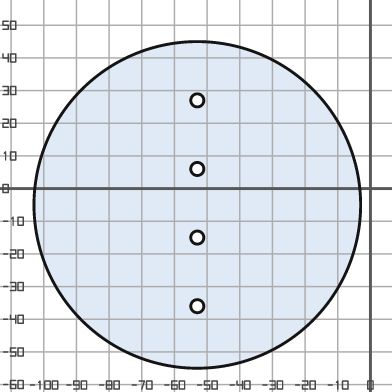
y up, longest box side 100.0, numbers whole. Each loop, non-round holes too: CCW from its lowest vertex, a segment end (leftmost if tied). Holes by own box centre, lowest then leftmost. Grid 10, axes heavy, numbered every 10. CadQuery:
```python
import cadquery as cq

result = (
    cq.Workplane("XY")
    .moveTo(-53.0, -5.0)
    .circle(50.0)
    .moveTo(-53.0, -36.0)
    .circle(2.0)
    .moveTo(-53.0, -15.0)
    .circle(2.0)
    .moveTo(-53.0, 6.0)
    .circle(2.0)
    .moveTo(-53.0, 27.0)
    .circle(2.0)
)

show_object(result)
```